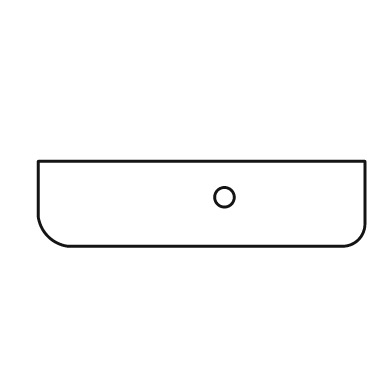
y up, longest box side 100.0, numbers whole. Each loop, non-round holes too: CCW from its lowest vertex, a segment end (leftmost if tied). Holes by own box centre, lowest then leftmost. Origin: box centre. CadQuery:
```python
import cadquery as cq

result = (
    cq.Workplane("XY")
    .moveTo(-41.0, -13.0)
    .lineTo(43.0, -13.0)
    .threePointArc((48.0, -11.0), (50.0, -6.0))
    .lineTo(50.0, 13.0)
    .lineTo(-50.0, 13.0)
    .lineTo(-50.0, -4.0)
    .threePointArc((-47.0, -10.0), (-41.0, -13.0))
    .close()
    .moveTo(7.0, 2.0)
    .circle(3.0)
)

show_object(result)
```